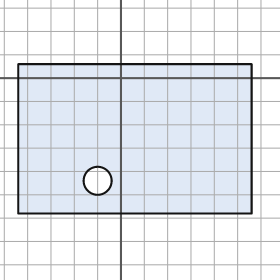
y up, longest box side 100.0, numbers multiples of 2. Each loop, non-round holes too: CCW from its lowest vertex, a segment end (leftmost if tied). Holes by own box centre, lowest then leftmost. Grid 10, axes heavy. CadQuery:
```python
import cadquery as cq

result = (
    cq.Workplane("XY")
    .moveTo(-44.0, -58.0)
    .lineTo(56.0, -58.0)
    .lineTo(56.0, 6.0)
    .lineTo(-44.0, 6.0)
    .close()
    .moveTo(-10.0, -44.0)
    .circle(6.0)
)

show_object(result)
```